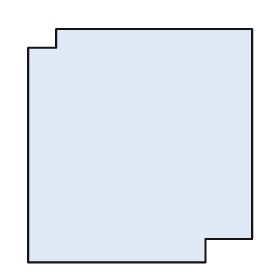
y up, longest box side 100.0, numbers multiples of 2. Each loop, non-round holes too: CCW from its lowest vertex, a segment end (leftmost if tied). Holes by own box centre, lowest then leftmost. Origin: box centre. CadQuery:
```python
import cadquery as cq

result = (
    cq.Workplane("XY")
    .moveTo(-48.0, -50.0)
    .lineTo(28.0, -50.0)
    .lineTo(28.0, -40.0)
    .lineTo(48.0, -40.0)
    .lineTo(48.0, 50.0)
    .lineTo(-36.0, 50.0)
    .lineTo(-36.0, 42.0)
    .lineTo(-48.0, 42.0)
    .close()
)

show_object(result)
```